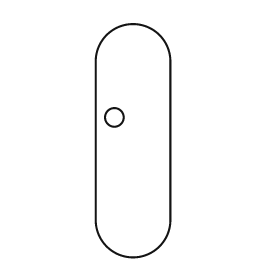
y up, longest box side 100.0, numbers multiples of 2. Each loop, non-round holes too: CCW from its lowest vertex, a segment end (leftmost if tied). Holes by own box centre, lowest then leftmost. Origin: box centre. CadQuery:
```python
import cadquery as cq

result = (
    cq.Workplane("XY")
    .moveTo(-16.0, -34.0)
    .threePointArc((0.0, -50.0), (16.0, -34.0))
    .lineTo(16.0, 34.0)
    .threePointArc((0.0, 50.0), (-16.0, 34.0))
    .close()
    .moveTo(-8.0, 10.0)
    .circle(4.0)
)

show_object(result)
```